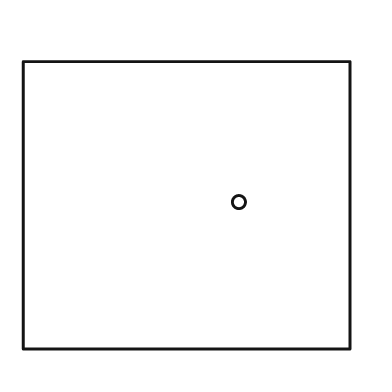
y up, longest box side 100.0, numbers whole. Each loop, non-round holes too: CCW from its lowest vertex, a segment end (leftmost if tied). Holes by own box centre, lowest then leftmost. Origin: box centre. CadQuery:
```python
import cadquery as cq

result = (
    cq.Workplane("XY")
    .moveTo(-50.0, -44.0)
    .lineTo(50.0, -44.0)
    .lineTo(50.0, 44.0)
    .lineTo(-50.0, 44.0)
    .close()
    .moveTo(16.0, 1.0)
    .circle(2.0)
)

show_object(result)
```